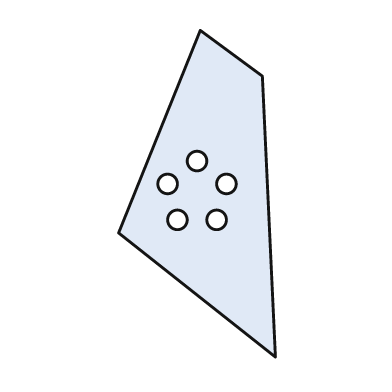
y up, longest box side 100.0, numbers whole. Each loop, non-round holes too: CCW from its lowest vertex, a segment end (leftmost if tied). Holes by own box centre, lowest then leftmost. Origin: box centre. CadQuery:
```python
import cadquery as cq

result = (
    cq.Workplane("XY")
    .moveTo(24.0, -50.0)
    .lineTo(20.0, 36.0)
    .lineTo(1.0, 50.0)
    .lineTo(-24.0, -12.0)
    .close()
    .moveTo(-6.0, -8.0)
    .circle(3.0)
    .moveTo(6.0, -8.0)
    .circle(3.0)
    .moveTo(-9.0, 3.0)
    .circle(3.0)
    .moveTo(9.0, 3.0)
    .circle(3.0)
    .moveTo(0.0, 10.0)
    .circle(3.0)
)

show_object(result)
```